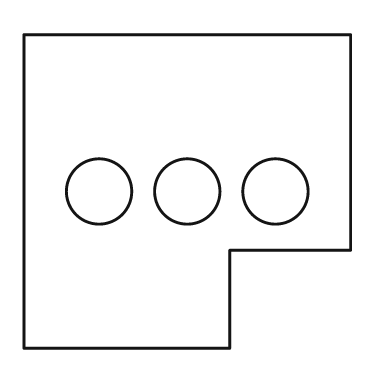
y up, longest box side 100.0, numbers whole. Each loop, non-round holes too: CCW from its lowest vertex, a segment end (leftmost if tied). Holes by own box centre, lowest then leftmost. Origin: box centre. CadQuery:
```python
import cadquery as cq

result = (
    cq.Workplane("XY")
    .moveTo(-50.0, -48.0)
    .lineTo(13.0, -48.0)
    .lineTo(13.0, -18.0)
    .lineTo(50.0, -18.0)
    .lineTo(50.0, 48.0)
    .lineTo(-50.0, 48.0)
    .close()
    .moveTo(-27.0, 0.0)
    .circle(10.0)
    .moveTo(0.0, 0.0)
    .circle(10.0)
    .moveTo(27.0, 0.0)
    .circle(10.0)
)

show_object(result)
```